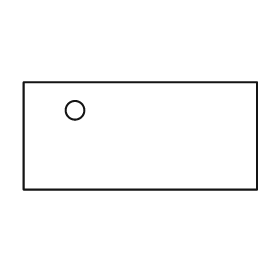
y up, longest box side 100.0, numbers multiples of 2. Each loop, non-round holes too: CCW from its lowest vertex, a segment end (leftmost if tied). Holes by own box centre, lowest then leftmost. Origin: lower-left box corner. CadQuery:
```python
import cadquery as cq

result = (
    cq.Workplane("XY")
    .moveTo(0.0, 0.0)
    .lineTo(100.0, 0.0)
    .lineTo(100.0, 46.0)
    .lineTo(0.0, 46.0)
    .close()
    .moveTo(22.0, 34.0)
    .circle(4.0)
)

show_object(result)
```